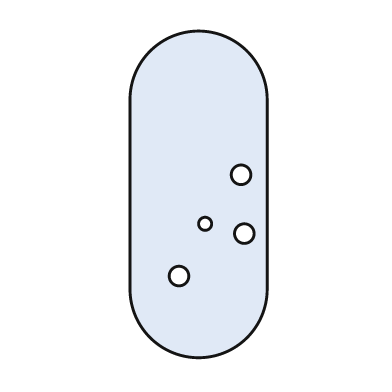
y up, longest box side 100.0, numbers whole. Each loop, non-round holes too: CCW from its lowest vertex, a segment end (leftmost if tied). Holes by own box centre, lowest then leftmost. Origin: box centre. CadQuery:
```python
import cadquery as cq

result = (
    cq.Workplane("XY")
    .moveTo(-21.0, -29.0)
    .threePointArc((0.0, -50.0), (21.0, -29.0))
    .lineTo(21.0, 29.0)
    .threePointArc((0.0, 50.0), (-21.0, 29.0))
    .close()
    .moveTo(-6.0, -25.0)
    .circle(3.0)
    .moveTo(14.0, -12.0)
    .circle(3.0)
    .moveTo(2.0, -9.0)
    .circle(2.0)
    .moveTo(13.0, 6.0)
    .circle(3.0)
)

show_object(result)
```